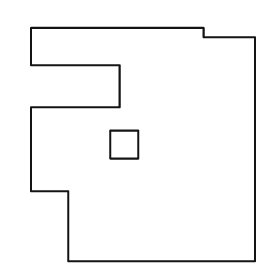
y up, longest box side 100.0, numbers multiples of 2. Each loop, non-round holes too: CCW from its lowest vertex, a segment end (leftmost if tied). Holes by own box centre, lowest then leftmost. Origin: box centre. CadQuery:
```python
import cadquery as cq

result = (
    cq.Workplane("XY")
    .moveTo(-32.0, -50.0)
    .lineTo(48.0, -50.0)
    .lineTo(48.0, 46.0)
    .lineTo(26.0, 46.0)
    .lineTo(26.0, 50.0)
    .lineTo(-48.0, 50.0)
    .lineTo(-48.0, 34.0)
    .lineTo(-10.0, 34.0)
    .lineTo(-10.0, 16.0)
    .lineTo(-48.0, 16.0)
    .lineTo(-48.0, -20.0)
    .lineTo(-32.0, -20.0)
    .close()
    .moveTo(-14.0, -6.0)
    .lineTo(-2.0, -6.0)
    .lineTo(-2.0, 6.0)
    .lineTo(-14.0, 6.0)
    .close()
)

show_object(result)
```